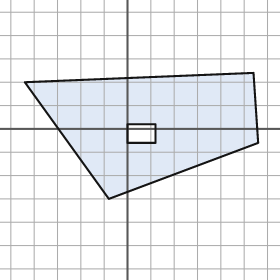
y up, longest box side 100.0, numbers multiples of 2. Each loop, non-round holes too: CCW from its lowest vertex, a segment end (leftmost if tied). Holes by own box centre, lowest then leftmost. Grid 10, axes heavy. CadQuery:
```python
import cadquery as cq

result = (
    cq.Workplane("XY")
    .moveTo(-8.0, -30.0)
    .lineTo(56.0, -6.0)
    .lineTo(54.0, 24.0)
    .lineTo(-44.0, 20.0)
    .close()
    .moveTo(0.0, -6.0)
    .lineTo(12.0, -6.0)
    .lineTo(12.0, 2.0)
    .lineTo(0.0, 2.0)
    .close()
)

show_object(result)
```